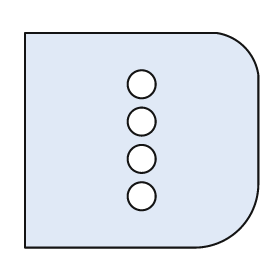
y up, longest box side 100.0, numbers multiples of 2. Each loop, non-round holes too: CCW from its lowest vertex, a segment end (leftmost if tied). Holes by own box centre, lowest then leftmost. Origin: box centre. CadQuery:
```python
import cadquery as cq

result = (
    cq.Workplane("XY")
    .moveTo(-50.0, -46.0)
    .lineTo(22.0, -46.0)
    .threePointArc((42.0, -38.0), (50.0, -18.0))
    .lineTo(50.0, 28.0)
    .threePointArc((44.0, 40.0), (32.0, 46.0))
    .lineTo(-50.0, 46.0)
    .close()
    .moveTo(0.0, -24.0)
    .circle(6.0)
    .moveTo(0.0, -8.0)
    .circle(6.0)
    .moveTo(0.0, 8.0)
    .circle(6.0)
    .moveTo(0.0, 24.0)
    .circle(6.0)
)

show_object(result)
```